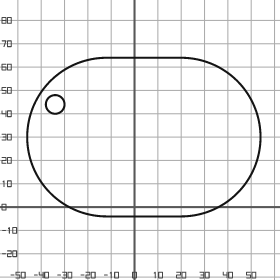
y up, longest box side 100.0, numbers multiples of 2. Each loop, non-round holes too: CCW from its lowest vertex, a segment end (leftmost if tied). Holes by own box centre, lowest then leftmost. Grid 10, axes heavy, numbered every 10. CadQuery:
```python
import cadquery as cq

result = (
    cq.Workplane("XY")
    .moveTo(-12.0, -4.0)
    .lineTo(20.0, -4.0)
    .threePointArc((54.0, 30.0), (20.0, 64.0))
    .lineTo(-12.0, 64.0)
    .threePointArc((-46.0, 30.0), (-12.0, -4.0))
    .close()
    .moveTo(-34.0, 44.0)
    .circle(4.0)
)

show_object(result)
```